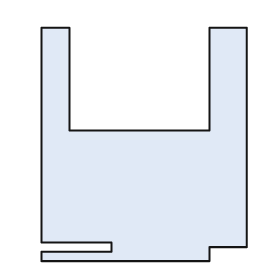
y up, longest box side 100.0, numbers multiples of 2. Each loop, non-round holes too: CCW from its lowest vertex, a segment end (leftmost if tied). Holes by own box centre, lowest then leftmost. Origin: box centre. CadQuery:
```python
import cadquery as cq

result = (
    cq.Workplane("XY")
    .moveTo(-44.0, -50.0)
    .lineTo(28.0, -50.0)
    .lineTo(28.0, -44.0)
    .lineTo(44.0, -44.0)
    .lineTo(44.0, 50.0)
    .lineTo(28.0, 50.0)
    .lineTo(28.0, 6.0)
    .lineTo(-32.0, 6.0)
    .lineTo(-32.0, 50.0)
    .lineTo(-44.0, 50.0)
    .lineTo(-44.0, -42.0)
    .lineTo(-14.0, -42.0)
    .lineTo(-14.0, -46.0)
    .lineTo(-44.0, -46.0)
    .close()
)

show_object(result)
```